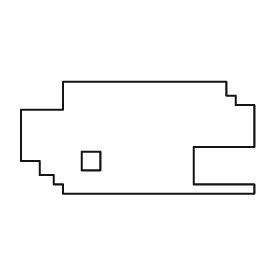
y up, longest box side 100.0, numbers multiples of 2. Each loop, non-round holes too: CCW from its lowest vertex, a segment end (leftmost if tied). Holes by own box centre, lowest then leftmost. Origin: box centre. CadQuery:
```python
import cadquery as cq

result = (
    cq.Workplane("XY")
    .moveTo(-32.0, -24.0)
    .lineTo(50.0, -24.0)
    .lineTo(50.0, -20.0)
    .lineTo(24.0, -20.0)
    .lineTo(24.0, -4.0)
    .lineTo(50.0, -4.0)
    .lineTo(50.0, 14.0)
    .lineTo(42.0, 14.0)
    .lineTo(42.0, 18.0)
    .lineTo(38.0, 18.0)
    .lineTo(38.0, 24.0)
    .lineTo(-32.0, 24.0)
    .lineTo(-32.0, 12.0)
    .lineTo(-50.0, 12.0)
    .lineTo(-50.0, -10.0)
    .lineTo(-42.0, -10.0)
    .lineTo(-42.0, -16.0)
    .lineTo(-36.0, -16.0)
    .lineTo(-36.0, -20.0)
    .lineTo(-32.0, -20.0)
    .close()
    .moveTo(-24.0, -14.0)
    .lineTo(-16.0, -14.0)
    .lineTo(-16.0, -6.0)
    .lineTo(-24.0, -6.0)
    .close()
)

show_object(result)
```